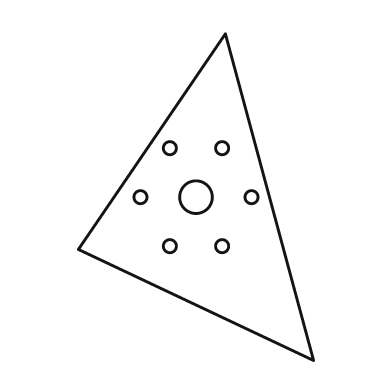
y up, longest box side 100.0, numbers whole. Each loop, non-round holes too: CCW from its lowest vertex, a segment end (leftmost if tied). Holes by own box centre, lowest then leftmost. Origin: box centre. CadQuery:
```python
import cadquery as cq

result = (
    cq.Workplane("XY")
    .moveTo(36.0, -50.0)
    .lineTo(9.0, 50.0)
    .lineTo(-36.0, -16.0)
    .close()
    .moveTo(-8.0, -15.0)
    .circle(2.0)
    .moveTo(8.0, -15.0)
    .circle(2.0)
    .moveTo(-17.0, 0.0)
    .circle(2.0)
    .moveTo(0.0, 0.0)
    .circle(5.0)
    .moveTo(17.0, 0.0)
    .circle(2.0)
    .moveTo(-8.0, 15.0)
    .circle(2.0)
    .moveTo(8.0, 15.0)
    .circle(2.0)
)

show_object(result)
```